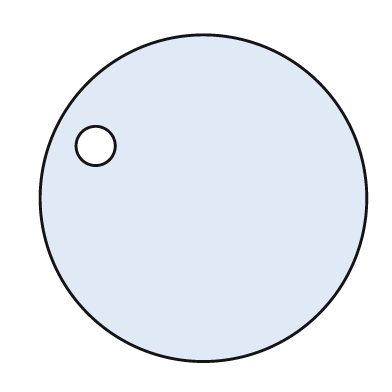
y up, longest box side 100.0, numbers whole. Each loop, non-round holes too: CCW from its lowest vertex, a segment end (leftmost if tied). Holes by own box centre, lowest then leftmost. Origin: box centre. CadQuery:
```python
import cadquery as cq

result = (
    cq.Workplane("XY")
    .moveTo(0.0, 0.0)
    .circle(50.0)
    .moveTo(-33.0, 16.0)
    .circle(6.0)
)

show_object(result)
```